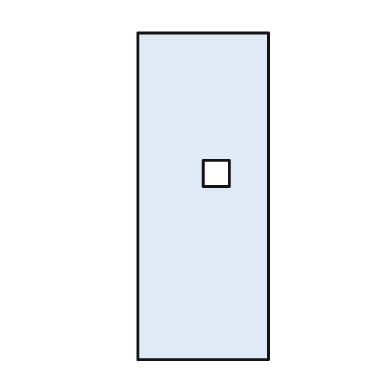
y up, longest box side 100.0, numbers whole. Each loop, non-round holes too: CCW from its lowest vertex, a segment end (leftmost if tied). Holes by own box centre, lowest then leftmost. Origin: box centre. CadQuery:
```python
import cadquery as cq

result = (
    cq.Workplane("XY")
    .moveTo(-20.0, -50.0)
    .lineTo(20.0, -50.0)
    .lineTo(20.0, 50.0)
    .lineTo(-20.0, 50.0)
    .close()
    .moveTo(0.0, 3.0)
    .lineTo(8.0, 3.0)
    .lineTo(8.0, 11.0)
    .lineTo(0.0, 11.0)
    .close()
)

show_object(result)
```